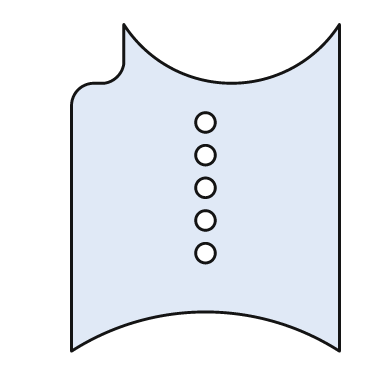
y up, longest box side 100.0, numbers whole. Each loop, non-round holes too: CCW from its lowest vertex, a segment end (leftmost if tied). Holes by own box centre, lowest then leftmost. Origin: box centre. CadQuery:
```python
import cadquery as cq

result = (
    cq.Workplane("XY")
    .moveTo(-41.0, -50.0)
    .threePointArc((0.0, -38.0), (41.0, -50.0))
    .lineTo(41.0, 50.0)
    .threePointArc((8.0, 32.0), (-25.0, 50.0))
    .lineTo(-25.0, 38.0)
    .threePointArc((-27.0, 34.0), (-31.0, 32.0))
    .lineTo(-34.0, 32.0)
    .threePointArc((-39.0, 30.0), (-41.0, 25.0))
    .close()
    .moveTo(0.0, -20.0)
    .circle(3.0)
    .moveTo(0.0, -10.0)
    .circle(3.0)
    .moveTo(0.0, 0.0)
    .circle(3.0)
    .moveTo(0.0, 10.0)
    .circle(3.0)
    .moveTo(0.0, 20.0)
    .circle(3.0)
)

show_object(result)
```